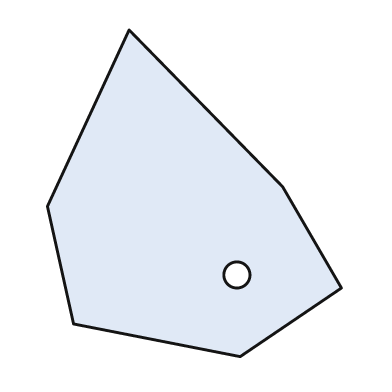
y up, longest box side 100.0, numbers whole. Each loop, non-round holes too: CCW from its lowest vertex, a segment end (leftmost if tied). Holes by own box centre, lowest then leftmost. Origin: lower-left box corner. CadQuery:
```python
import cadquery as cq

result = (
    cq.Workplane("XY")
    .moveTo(59.0, 0.0)
    .lineTo(90.0, 21.0)
    .lineTo(72.0, 52.0)
    .lineTo(25.0, 100.0)
    .lineTo(0.0, 46.0)
    .lineTo(8.0, 10.0)
    .close()
    .moveTo(58.0, 25.0)
    .circle(4.0)
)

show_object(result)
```